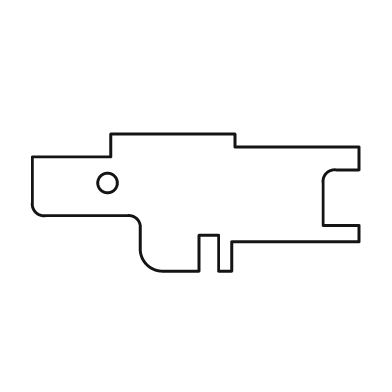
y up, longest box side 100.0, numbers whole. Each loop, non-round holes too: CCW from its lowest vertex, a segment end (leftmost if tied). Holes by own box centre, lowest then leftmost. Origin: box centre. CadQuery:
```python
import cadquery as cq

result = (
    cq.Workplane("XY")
    .moveTo(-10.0, -21.0)
    .lineTo(1.0, -21.0)
    .lineTo(1.0, -10.0)
    .lineTo(7.0, -10.0)
    .lineTo(7.0, -21.0)
    .lineTo(11.0, -21.0)
    .lineTo(11.0, -12.0)
    .lineTo(50.0, -12.0)
    .lineTo(50.0, -7.0)
    .lineTo(39.0, -7.0)
    .lineTo(39.0, 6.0)
    .threePointArc((40.0, 9.0), (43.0, 10.0))
    .lineTo(50.0, 10.0)
    .lineTo(50.0, 17.0)
    .lineTo(12.0, 17.0)
    .lineTo(12.0, 21.0)
    .lineTo(-26.0, 21.0)
    .lineTo(-26.0, 14.0)
    .lineTo(-50.0, 14.0)
    .lineTo(-50.0, 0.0)
    .threePointArc((-49.0, -3.0), (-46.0, -4.0))
    .lineTo(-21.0, -4.0)
    .threePointArc((-18.0, -5.0), (-17.0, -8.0))
    .lineTo(-17.0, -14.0)
    .threePointArc((-15.0, -19.0), (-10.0, -21.0))
    .close()
    .moveTo(-27.0, 6.0)
    .circle(3.0)
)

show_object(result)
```